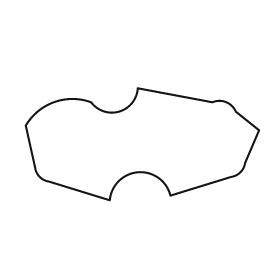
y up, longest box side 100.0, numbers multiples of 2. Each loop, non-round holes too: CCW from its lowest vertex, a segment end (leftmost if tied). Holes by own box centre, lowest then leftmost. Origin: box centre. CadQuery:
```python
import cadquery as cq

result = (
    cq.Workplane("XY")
    .moveTo(-14.0, -24.0)
    .threePointArc((-2.0, -12.0), (12.0, -22.0))
    .lineTo(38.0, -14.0)
    .threePointArc((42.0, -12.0), (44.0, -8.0))
    .lineTo(50.0, 6.0)
    .lineTo(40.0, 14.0)
    .threePointArc((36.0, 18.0), (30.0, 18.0))
    .lineTo(-2.0, 24.0)
    .threePointArc((-10.0, 14.0), (-22.0, 18.0))
    .threePointArc((-38.0, 18.0), (-50.0, 8.0))
    .lineTo(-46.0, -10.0)
    .threePointArc((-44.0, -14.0), (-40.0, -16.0))
    .close()
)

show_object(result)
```